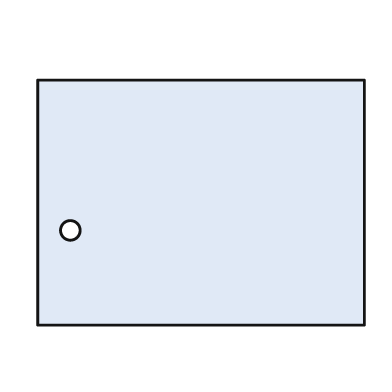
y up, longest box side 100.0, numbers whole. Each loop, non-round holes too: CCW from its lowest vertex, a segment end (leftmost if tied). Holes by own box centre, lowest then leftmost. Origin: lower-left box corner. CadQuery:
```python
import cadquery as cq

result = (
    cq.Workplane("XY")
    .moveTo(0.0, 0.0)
    .lineTo(100.0, 0.0)
    .lineTo(100.0, 75.0)
    .lineTo(0.0, 75.0)
    .close()
    .moveTo(10.0, 29.0)
    .circle(3.0)
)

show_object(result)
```